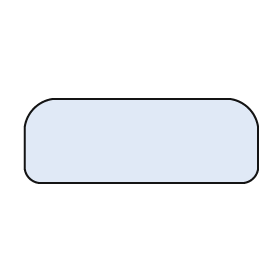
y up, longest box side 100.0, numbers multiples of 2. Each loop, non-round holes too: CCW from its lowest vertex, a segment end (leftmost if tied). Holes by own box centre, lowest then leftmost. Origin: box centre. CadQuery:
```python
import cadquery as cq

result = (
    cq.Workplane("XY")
    .moveTo(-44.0, -18.0)
    .lineTo(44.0, -18.0)
    .threePointArc((48.0, -16.0), (50.0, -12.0))
    .lineTo(50.0, 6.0)
    .threePointArc((46.0, 14.0), (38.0, 18.0))
    .lineTo(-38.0, 18.0)
    .threePointArc((-46.0, 14.0), (-50.0, 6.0))
    .lineTo(-50.0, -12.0)
    .threePointArc((-48.0, -16.0), (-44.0, -18.0))
    .close()
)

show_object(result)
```